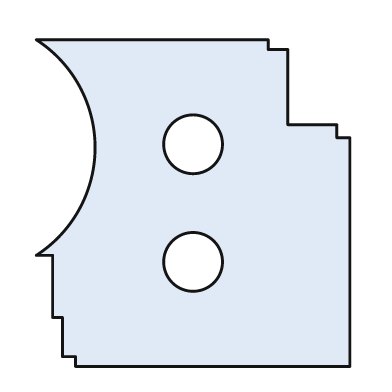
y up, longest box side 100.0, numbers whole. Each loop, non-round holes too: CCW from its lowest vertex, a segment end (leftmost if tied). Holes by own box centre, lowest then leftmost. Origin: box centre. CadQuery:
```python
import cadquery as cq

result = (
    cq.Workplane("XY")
    .moveTo(-36.0, -50.0)
    .lineTo(48.0, -50.0)
    .lineTo(48.0, 20.0)
    .lineTo(44.0, 20.0)
    .lineTo(44.0, 24.0)
    .lineTo(29.0, 24.0)
    .lineTo(29.0, 47.0)
    .lineTo(23.0, 47.0)
    .lineTo(23.0, 50.0)
    .lineTo(-48.0, 50.0)
    .threePointArc((-30.0, 17.0), (-48.0, -16.0))
    .lineTo(-43.0, -16.0)
    .lineTo(-43.0, -35.0)
    .lineTo(-40.0, -35.0)
    .lineTo(-40.0, -47.0)
    .lineTo(-36.0, -47.0)
    .close()
    .moveTo(0.0, -18.0)
    .circle(9.0)
    .moveTo(0.0, 18.0)
    .circle(9.0)
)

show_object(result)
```